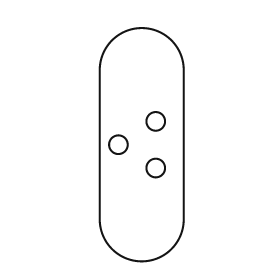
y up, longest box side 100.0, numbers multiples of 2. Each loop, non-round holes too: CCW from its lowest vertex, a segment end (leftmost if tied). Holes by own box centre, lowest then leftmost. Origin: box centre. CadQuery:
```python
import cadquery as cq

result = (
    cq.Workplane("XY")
    .moveTo(-18.0, -32.0)
    .threePointArc((0.0, -50.0), (18.0, -32.0))
    .lineTo(18.0, 32.0)
    .threePointArc((0.0, 50.0), (-18.0, 32.0))
    .close()
    .moveTo(6.0, -10.0)
    .circle(4.0)
    .moveTo(-10.0, 0.0)
    .circle(4.0)
    .moveTo(6.0, 10.0)
    .circle(4.0)
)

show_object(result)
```